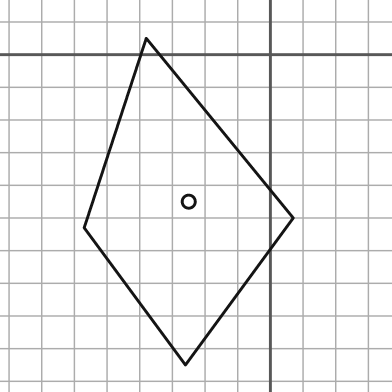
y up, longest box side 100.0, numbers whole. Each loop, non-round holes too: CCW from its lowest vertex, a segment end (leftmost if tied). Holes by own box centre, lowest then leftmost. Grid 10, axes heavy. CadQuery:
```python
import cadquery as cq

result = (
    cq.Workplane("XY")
    .moveTo(-26.0, -95.0)
    .lineTo(7.0, -50.0)
    .lineTo(-38.0, 5.0)
    .lineTo(-57.0, -53.0)
    .close()
    .moveTo(-25.0, -45.0)
    .circle(2.0)
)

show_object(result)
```